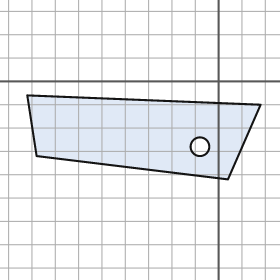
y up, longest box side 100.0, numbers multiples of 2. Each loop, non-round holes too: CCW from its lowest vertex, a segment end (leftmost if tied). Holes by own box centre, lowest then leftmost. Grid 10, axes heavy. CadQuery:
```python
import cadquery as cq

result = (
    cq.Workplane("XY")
    .moveTo(4.0, -42.0)
    .lineTo(18.0, -10.0)
    .lineTo(-82.0, -6.0)
    .lineTo(-78.0, -32.0)
    .close()
    .moveTo(-8.0, -28.0)
    .circle(4.0)
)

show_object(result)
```